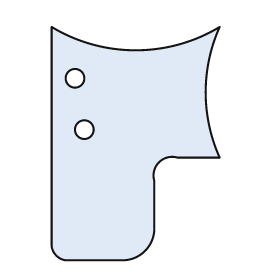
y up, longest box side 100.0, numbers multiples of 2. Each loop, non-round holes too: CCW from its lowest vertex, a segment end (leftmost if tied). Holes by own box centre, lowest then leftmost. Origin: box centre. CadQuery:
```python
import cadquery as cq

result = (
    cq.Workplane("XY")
    .moveTo(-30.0, -50.0)
    .lineTo(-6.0, -50.0)
    .threePointArc((4.0, -46.0), (8.0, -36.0))
    .lineTo(8.0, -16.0)
    .threePointArc((10.0, -8.0), (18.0, -6.0))
    .lineTo(36.0, -6.0)
    .threePointArc((30.0, 22.0), (36.0, 50.0))
    .threePointArc((0.0, 40.0), (-36.0, 50.0))
    .lineTo(-36.0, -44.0)
    .threePointArc((-34.0, -48.0), (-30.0, -50.0))
    .close()
    .moveTo(-22.0, 6.0)
    .circle(4.0)
    .moveTo(-26.0, 28.0)
    .circle(4.0)
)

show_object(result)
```